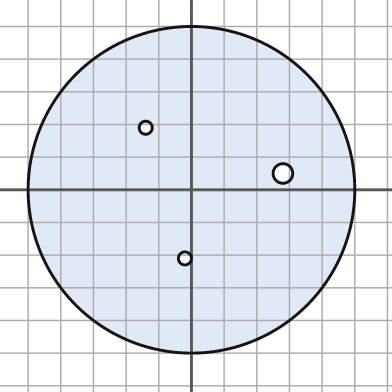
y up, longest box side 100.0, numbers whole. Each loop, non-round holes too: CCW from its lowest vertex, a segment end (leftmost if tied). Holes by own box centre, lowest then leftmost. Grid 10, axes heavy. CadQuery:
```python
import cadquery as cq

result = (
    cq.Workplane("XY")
    .moveTo(0.0, 0.0)
    .circle(50.0)
    .moveTo(-2.0, -21.0)
    .circle(2.0)
    .moveTo(28.0, 5.0)
    .circle(3.0)
    .moveTo(-14.0, 19.0)
    .circle(2.0)
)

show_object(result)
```